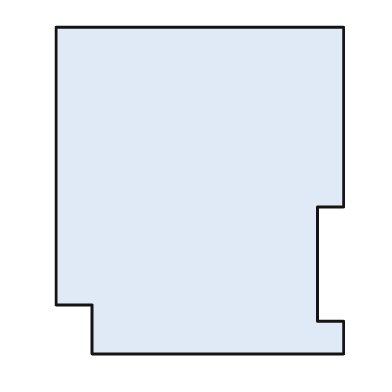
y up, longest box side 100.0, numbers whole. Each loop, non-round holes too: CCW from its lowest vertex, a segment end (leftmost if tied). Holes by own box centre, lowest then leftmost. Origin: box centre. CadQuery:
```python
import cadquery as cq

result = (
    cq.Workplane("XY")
    .moveTo(-33.0, -50.0)
    .lineTo(44.0, -50.0)
    .lineTo(44.0, -40.0)
    .lineTo(36.0, -40.0)
    .lineTo(36.0, -5.0)
    .lineTo(44.0, -5.0)
    .lineTo(44.0, 50.0)
    .lineTo(-44.0, 50.0)
    .lineTo(-44.0, -35.0)
    .lineTo(-33.0, -35.0)
    .close()
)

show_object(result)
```